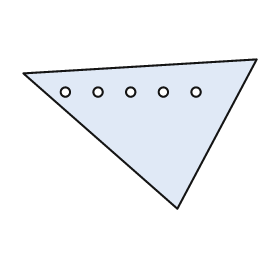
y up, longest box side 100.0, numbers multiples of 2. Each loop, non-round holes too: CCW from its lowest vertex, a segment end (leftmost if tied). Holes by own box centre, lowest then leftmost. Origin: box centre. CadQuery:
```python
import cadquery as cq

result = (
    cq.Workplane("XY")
    .moveTo(16.0, -32.0)
    .lineTo(50.0, 32.0)
    .lineTo(-50.0, 26.0)
    .close()
    .moveTo(-32.0, 18.0)
    .circle(2.0)
    .moveTo(-18.0, 18.0)
    .circle(2.0)
    .moveTo(-4.0, 18.0)
    .circle(2.0)
    .moveTo(10.0, 18.0)
    .circle(2.0)
    .moveTo(24.0, 18.0)
    .circle(2.0)
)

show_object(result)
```